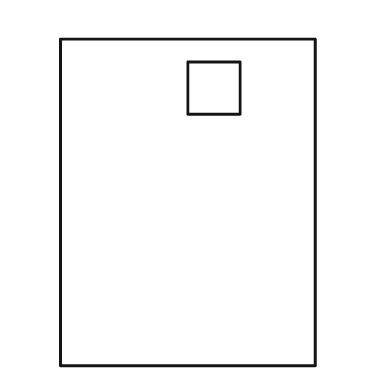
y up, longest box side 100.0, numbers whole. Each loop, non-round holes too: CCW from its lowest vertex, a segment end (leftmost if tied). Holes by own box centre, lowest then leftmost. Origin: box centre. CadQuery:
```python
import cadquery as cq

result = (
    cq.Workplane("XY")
    .moveTo(-39.0, -50.0)
    .lineTo(39.0, -50.0)
    .lineTo(39.0, 50.0)
    .lineTo(-39.0, 50.0)
    .close()
    .moveTo(0.0, 27.0)
    .lineTo(16.0, 27.0)
    .lineTo(16.0, 43.0)
    .lineTo(0.0, 43.0)
    .close()
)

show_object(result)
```